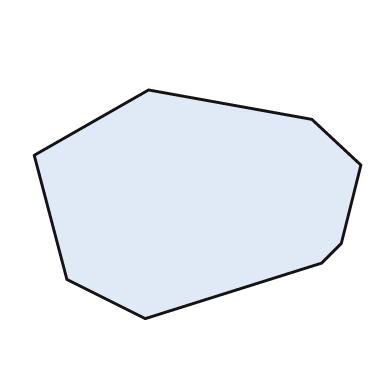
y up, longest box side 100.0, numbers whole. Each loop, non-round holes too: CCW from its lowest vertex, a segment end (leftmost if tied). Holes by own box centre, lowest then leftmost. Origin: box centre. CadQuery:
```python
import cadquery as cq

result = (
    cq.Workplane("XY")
    .moveTo(-16.0, -35.0)
    .lineTo(38.0, -18.0)
    .lineTo(44.0, -12.0)
    .lineTo(50.0, 12.0)
    .lineTo(35.0, 26.0)
    .lineTo(-15.0, 35.0)
    .lineTo(-50.0, 15.0)
    .lineTo(-40.0, -23.0)
    .close()
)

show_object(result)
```